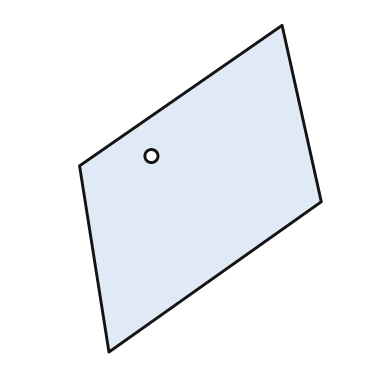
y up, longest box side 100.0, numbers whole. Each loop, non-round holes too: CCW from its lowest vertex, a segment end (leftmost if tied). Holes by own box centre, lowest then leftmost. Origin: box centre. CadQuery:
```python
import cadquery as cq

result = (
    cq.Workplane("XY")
    .moveTo(-28.0, -50.0)
    .lineTo(37.0, -4.0)
    .lineTo(25.0, 50.0)
    .lineTo(-37.0, 7.0)
    .close()
    .moveTo(-15.0, 10.0)
    .circle(2.0)
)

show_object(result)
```